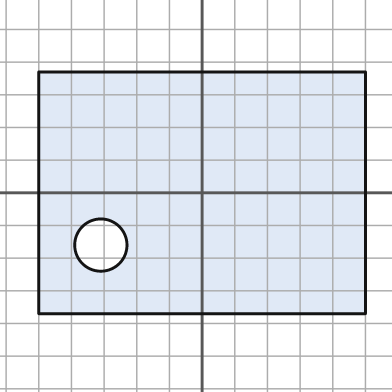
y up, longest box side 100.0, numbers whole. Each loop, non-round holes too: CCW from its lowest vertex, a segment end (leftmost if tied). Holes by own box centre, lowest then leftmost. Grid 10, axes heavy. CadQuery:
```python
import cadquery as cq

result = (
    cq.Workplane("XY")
    .moveTo(-50.0, -37.0)
    .lineTo(50.0, -37.0)
    .lineTo(50.0, 37.0)
    .lineTo(-50.0, 37.0)
    .close()
    .moveTo(-31.0, -16.0)
    .circle(8.0)
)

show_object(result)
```